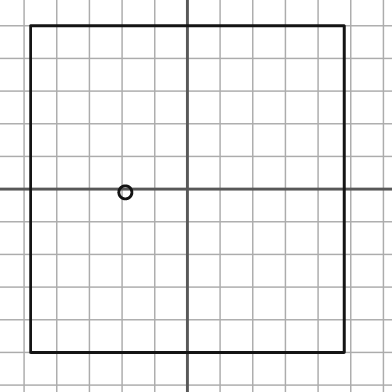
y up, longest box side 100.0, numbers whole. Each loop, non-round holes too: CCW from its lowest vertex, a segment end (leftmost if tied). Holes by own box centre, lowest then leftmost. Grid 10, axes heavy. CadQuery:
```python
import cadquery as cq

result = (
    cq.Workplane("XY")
    .moveTo(-48.0, -50.0)
    .lineTo(48.0, -50.0)
    .lineTo(48.0, 50.0)
    .lineTo(-48.0, 50.0)
    .close()
    .moveTo(-19.0, -1.0)
    .circle(2.0)
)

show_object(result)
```